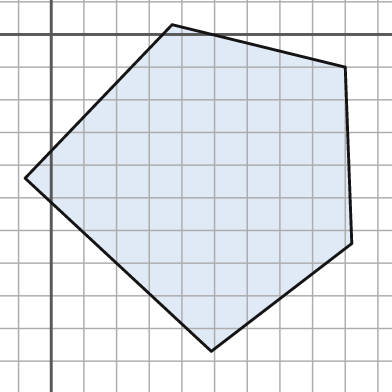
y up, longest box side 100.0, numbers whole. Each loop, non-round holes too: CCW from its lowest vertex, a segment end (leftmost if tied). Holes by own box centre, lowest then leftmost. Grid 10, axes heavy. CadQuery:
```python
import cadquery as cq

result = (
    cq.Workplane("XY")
    .moveTo(49.0, -97.0)
    .lineTo(92.0, -64.0)
    .lineTo(90.0, -10.0)
    .lineTo(37.0, 3.0)
    .lineTo(-8.0, -44.0)
    .close()
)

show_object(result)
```